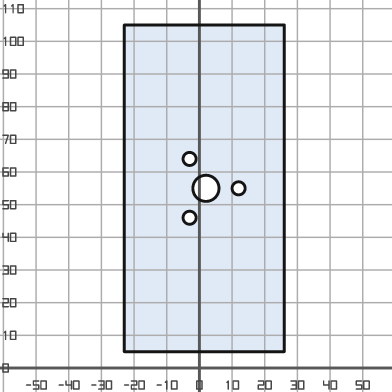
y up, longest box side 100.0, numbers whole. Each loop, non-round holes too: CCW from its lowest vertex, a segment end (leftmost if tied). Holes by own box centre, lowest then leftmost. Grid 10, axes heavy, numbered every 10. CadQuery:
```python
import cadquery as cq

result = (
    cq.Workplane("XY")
    .moveTo(-23.0, 5.0)
    .lineTo(26.0, 5.0)
    .lineTo(26.0, 105.0)
    .lineTo(-23.0, 105.0)
    .close()
    .moveTo(-3.0, 46.0)
    .circle(2.0)
    .moveTo(2.0, 55.0)
    .circle(4.0)
    .moveTo(12.0, 55.0)
    .circle(2.0)
    .moveTo(-3.0, 64.0)
    .circle(2.0)
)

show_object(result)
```